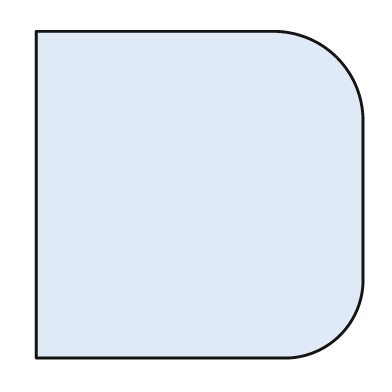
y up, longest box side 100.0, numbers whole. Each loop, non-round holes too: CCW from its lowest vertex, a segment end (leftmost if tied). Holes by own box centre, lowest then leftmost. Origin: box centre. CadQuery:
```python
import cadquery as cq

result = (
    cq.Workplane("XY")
    .moveTo(-50.0, -50.0)
    .lineTo(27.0, -50.0)
    .threePointArc((43.0, -43.0), (50.0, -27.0))
    .lineTo(50.0, 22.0)
    .threePointArc((42.0, 42.0), (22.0, 50.0))
    .lineTo(-50.0, 50.0)
    .close()
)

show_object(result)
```